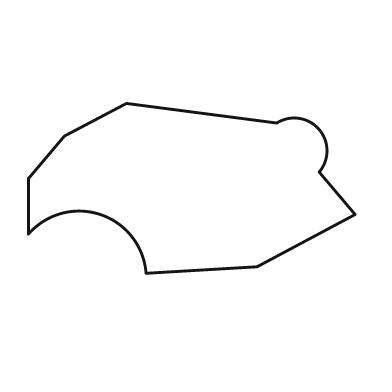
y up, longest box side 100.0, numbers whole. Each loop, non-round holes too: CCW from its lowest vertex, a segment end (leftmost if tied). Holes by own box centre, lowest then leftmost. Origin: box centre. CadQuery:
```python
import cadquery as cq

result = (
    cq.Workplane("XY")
    .moveTo(-14.0, -26.0)
    .lineTo(20.0, -24.0)
    .lineTo(50.0, -8.0)
    .lineTo(39.0, 5.0)
    .threePointArc((39.0, 18.0), (26.0, 20.0))
    .lineTo(-20.0, 26.0)
    .lineTo(-39.0, 16.0)
    .lineTo(-50.0, 3.0)
    .lineTo(-50.0, -14.0)
    .threePointArc((-28.0, -8.0), (-14.0, -26.0))
    .close()
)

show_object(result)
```